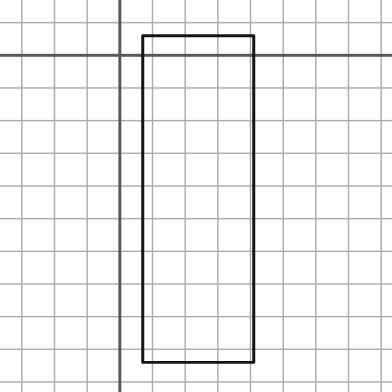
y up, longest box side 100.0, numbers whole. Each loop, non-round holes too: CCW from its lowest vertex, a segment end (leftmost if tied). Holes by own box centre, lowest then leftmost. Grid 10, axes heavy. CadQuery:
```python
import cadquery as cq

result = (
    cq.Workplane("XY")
    .moveTo(7.0, -94.0)
    .lineTo(41.0, -94.0)
    .lineTo(41.0, 6.0)
    .lineTo(7.0, 6.0)
    .close()
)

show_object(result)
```